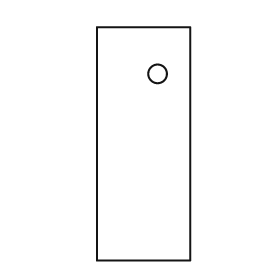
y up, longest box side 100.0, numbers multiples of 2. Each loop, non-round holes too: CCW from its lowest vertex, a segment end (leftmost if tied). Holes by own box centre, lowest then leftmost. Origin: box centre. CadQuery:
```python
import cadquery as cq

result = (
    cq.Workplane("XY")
    .moveTo(-20.0, -50.0)
    .lineTo(20.0, -50.0)
    .lineTo(20.0, 50.0)
    .lineTo(-20.0, 50.0)
    .close()
    .moveTo(6.0, 30.0)
    .circle(4.0)
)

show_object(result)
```